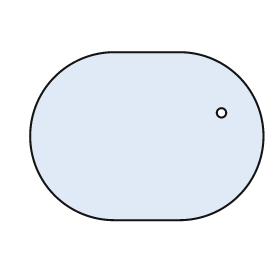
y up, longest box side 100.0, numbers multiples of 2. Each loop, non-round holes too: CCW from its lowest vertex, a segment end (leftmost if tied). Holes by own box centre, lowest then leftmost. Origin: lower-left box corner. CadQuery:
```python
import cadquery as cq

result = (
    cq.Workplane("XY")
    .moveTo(36.0, 0.0)
    .lineTo(64.0, 0.0)
    .threePointArc((100.0, 36.0), (64.0, 72.0))
    .lineTo(36.0, 72.0)
    .threePointArc((0.0, 36.0), (36.0, 0.0))
    .close()
    .moveTo(82.0, 46.0)
    .circle(2.0)
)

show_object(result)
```